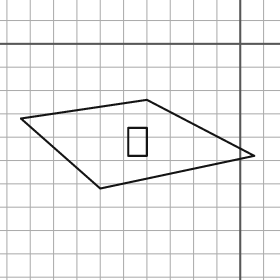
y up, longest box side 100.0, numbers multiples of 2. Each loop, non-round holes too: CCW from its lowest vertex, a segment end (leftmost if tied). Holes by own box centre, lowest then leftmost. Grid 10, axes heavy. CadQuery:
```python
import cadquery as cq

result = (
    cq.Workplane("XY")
    .moveTo(-60.0, -62.0)
    .lineTo(6.0, -48.0)
    .lineTo(-40.0, -24.0)
    .lineTo(-94.0, -32.0)
    .close()
    .moveTo(-48.0, -48.0)
    .lineTo(-40.0, -48.0)
    .lineTo(-40.0, -36.0)
    .lineTo(-48.0, -36.0)
    .close()
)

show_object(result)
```